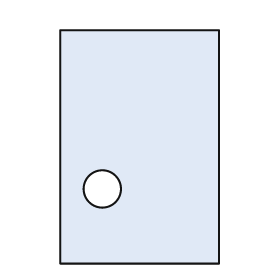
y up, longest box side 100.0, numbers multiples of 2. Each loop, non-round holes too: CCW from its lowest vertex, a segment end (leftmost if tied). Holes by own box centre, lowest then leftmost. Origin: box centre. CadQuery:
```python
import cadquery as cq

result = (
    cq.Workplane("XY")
    .moveTo(-34.0, -50.0)
    .lineTo(34.0, -50.0)
    .lineTo(34.0, 50.0)
    .lineTo(-34.0, 50.0)
    .close()
    .moveTo(-16.0, -18.0)
    .circle(8.0)
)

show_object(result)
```